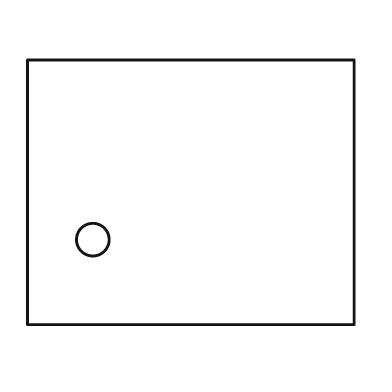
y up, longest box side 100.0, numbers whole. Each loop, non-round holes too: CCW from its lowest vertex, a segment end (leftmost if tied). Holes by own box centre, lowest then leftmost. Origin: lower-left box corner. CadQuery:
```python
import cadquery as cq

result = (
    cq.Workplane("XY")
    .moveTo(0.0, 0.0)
    .lineTo(100.0, 0.0)
    .lineTo(100.0, 81.0)
    .lineTo(0.0, 81.0)
    .close()
    .moveTo(20.0, 26.0)
    .circle(5.0)
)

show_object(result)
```